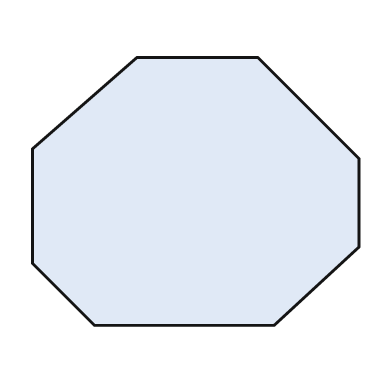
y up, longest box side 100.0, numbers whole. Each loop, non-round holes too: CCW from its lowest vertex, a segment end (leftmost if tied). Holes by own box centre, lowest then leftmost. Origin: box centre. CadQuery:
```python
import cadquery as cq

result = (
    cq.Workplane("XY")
    .moveTo(-31.0, -41.0)
    .lineTo(24.0, -41.0)
    .lineTo(50.0, -17.0)
    .lineTo(50.0, 10.0)
    .lineTo(19.0, 41.0)
    .lineTo(-18.0, 41.0)
    .lineTo(-50.0, 13.0)
    .lineTo(-50.0, -22.0)
    .close()
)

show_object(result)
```